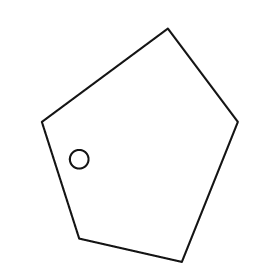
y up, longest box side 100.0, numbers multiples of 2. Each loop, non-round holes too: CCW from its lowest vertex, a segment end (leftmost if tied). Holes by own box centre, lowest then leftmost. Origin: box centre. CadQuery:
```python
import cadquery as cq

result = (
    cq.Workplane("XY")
    .moveTo(18.0, -50.0)
    .lineTo(42.0, 10.0)
    .lineTo(12.0, 50.0)
    .lineTo(-42.0, 10.0)
    .lineTo(-26.0, -40.0)
    .close()
    .moveTo(-26.0, -6.0)
    .circle(4.0)
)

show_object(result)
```